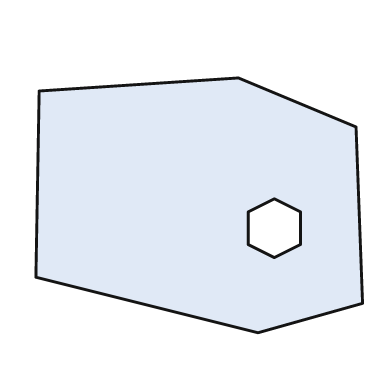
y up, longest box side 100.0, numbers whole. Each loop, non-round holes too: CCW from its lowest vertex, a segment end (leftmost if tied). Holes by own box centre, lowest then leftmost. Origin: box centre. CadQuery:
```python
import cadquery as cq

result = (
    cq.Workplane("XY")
    .moveTo(18.0, -39.0)
    .lineTo(50.0, -30.0)
    .lineTo(48.0, 24.0)
    .lineTo(12.0, 39.0)
    .lineTo(-49.0, 35.0)
    .lineTo(-50.0, -22.0)
    .close()
    .moveTo(23.0, -16.0)
    .lineTo(31.0, -12.0)
    .lineTo(31.0, -2.0)
    .lineTo(23.0, 2.0)
    .lineTo(15.0, -2.0)
    .lineTo(15.0, -12.0)
    .close()
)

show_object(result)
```